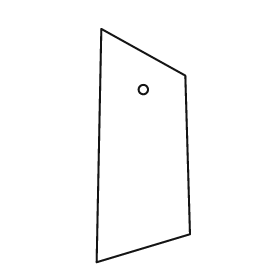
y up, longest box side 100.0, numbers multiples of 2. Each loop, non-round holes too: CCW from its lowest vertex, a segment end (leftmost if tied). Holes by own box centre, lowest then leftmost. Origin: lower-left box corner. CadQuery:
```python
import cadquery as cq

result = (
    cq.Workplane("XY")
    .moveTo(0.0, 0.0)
    .lineTo(40.0, 12.0)
    .lineTo(38.0, 80.0)
    .lineTo(2.0, 100.0)
    .close()
    .moveTo(20.0, 74.0)
    .circle(2.0)
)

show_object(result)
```